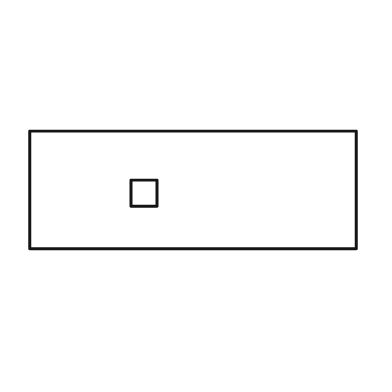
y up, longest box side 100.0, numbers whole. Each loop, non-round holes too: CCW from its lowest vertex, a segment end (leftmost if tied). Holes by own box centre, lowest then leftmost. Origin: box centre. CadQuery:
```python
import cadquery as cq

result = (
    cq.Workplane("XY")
    .moveTo(-50.0, -18.0)
    .lineTo(50.0, -18.0)
    .lineTo(50.0, 18.0)
    .lineTo(-50.0, 18.0)
    .close()
    .moveTo(-19.0, -5.0)
    .lineTo(-11.0, -5.0)
    .lineTo(-11.0, 3.0)
    .lineTo(-19.0, 3.0)
    .close()
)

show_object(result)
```